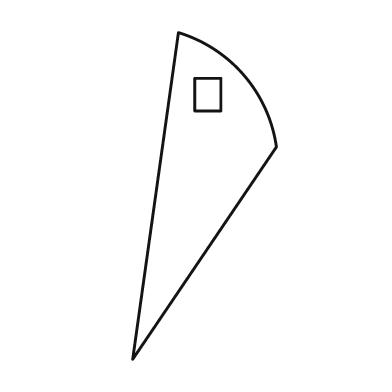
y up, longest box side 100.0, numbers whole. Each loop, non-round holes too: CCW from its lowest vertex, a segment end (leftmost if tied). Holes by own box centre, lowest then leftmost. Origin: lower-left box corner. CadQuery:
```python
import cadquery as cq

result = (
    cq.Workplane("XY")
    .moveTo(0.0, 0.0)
    .lineTo(44.0, 65.0)
    .threePointArc((34.0, 87.0), (14.0, 100.0))
    .close()
    .moveTo(19.0, 76.0)
    .lineTo(27.0, 76.0)
    .lineTo(27.0, 86.0)
    .lineTo(19.0, 86.0)
    .close()
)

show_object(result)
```